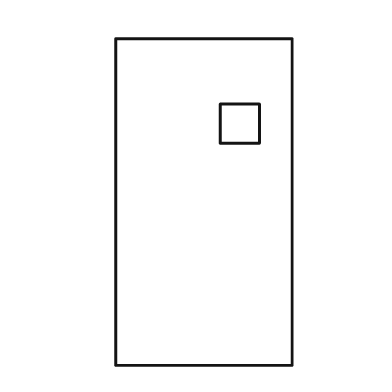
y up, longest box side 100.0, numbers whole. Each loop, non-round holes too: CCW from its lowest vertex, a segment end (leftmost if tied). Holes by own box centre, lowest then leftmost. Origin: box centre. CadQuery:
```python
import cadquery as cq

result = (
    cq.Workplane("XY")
    .moveTo(-27.0, -50.0)
    .lineTo(27.0, -50.0)
    .lineTo(27.0, 50.0)
    .lineTo(-27.0, 50.0)
    .close()
    .moveTo(5.0, 18.0)
    .lineTo(17.0, 18.0)
    .lineTo(17.0, 30.0)
    .lineTo(5.0, 30.0)
    .close()
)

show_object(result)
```